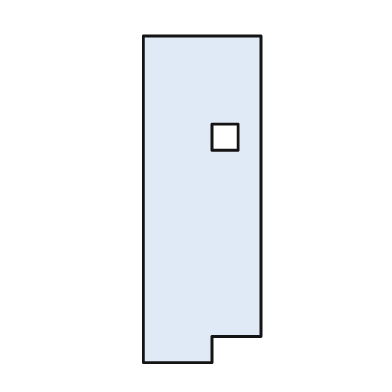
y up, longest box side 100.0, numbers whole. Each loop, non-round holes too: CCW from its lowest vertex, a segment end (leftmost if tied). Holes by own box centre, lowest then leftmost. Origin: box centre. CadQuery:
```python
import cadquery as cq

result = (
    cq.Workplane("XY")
    .moveTo(-18.0, -50.0)
    .lineTo(3.0, -50.0)
    .lineTo(3.0, -42.0)
    .lineTo(18.0, -42.0)
    .lineTo(18.0, 50.0)
    .lineTo(-18.0, 50.0)
    .close()
    .moveTo(3.0, 15.0)
    .lineTo(11.0, 15.0)
    .lineTo(11.0, 23.0)
    .lineTo(3.0, 23.0)
    .close()
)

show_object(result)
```